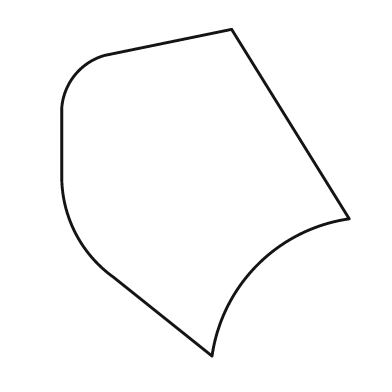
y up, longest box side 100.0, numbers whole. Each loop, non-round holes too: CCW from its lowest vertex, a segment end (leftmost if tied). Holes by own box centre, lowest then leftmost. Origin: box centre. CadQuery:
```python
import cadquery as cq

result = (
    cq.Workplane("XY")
    .moveTo(2.0, -50.0)
    .threePointArc((16.0, -22.0), (44.0, -8.0))
    .lineTo(8.0, 50.0)
    .lineTo(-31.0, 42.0)
    .threePointArc((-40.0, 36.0), (-44.0, 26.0))
    .lineTo(-44.0, 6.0)
    .threePointArc((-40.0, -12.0), (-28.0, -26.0))
    .close()
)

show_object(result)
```